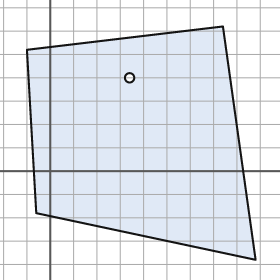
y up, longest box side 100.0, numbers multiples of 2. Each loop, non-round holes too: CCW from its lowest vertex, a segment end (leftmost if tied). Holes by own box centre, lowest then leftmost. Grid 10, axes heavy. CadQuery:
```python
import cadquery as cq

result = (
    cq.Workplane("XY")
    .moveTo(88.0, -38.0)
    .lineTo(74.0, 62.0)
    .lineTo(-10.0, 52.0)
    .lineTo(-6.0, -18.0)
    .close()
    .moveTo(34.0, 40.0)
    .circle(2.0)
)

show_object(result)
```